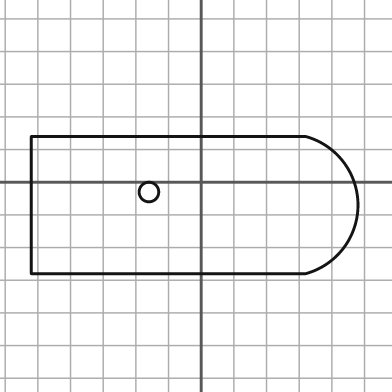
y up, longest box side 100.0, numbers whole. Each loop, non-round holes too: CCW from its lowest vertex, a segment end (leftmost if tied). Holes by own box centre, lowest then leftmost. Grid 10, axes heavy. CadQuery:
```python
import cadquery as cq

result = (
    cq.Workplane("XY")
    .moveTo(-52.0, -28.0)
    .lineTo(32.0, -28.0)
    .threePointArc((48.0, -7.0), (32.0, 14.0))
    .lineTo(-52.0, 14.0)
    .close()
    .moveTo(-16.0, -3.0)
    .circle(3.0)
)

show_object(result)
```